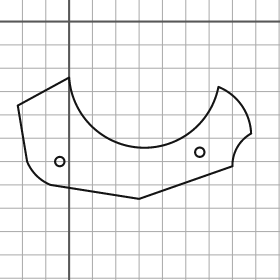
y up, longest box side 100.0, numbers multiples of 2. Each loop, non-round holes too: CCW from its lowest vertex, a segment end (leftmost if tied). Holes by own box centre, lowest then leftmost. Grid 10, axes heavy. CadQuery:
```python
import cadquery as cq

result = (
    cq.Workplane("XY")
    .moveTo(30.0, -76.0)
    .lineTo(70.0, -62.0)
    .threePointArc((72.0, -54.0), (78.0, -48.0))
    .threePointArc((74.0, -36.0), (64.0, -28.0))
    .threePointArc((30.0, -54.0), (0.0, -24.0))
    .lineTo(-22.0, -36.0)
    .lineTo(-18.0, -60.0)
    .threePointArc((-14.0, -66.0), (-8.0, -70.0))
    .close()
    .moveTo(-4.0, -60.0)
    .circle(2.0)
    .moveTo(56.0, -56.0)
    .circle(2.0)
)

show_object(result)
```